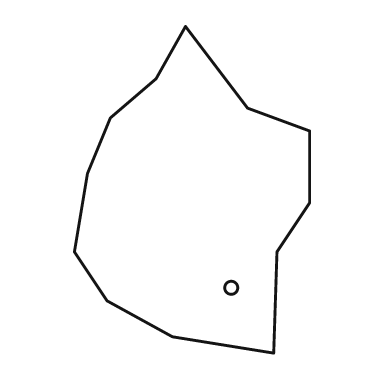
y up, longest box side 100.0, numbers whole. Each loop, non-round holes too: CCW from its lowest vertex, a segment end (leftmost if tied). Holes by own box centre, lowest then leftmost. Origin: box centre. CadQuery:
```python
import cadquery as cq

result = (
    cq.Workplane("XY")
    .moveTo(25.0, -50.0)
    .lineTo(26.0, -19.0)
    .lineTo(36.0, -4.0)
    .lineTo(36.0, 18.0)
    .lineTo(17.0, 25.0)
    .lineTo(-2.0, 50.0)
    .lineTo(-11.0, 34.0)
    .lineTo(-25.0, 22.0)
    .lineTo(-32.0, 5.0)
    .lineTo(-36.0, -19.0)
    .lineTo(-26.0, -34.0)
    .lineTo(-6.0, -45.0)
    .close()
    .moveTo(12.0, -30.0)
    .circle(2.0)
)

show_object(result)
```